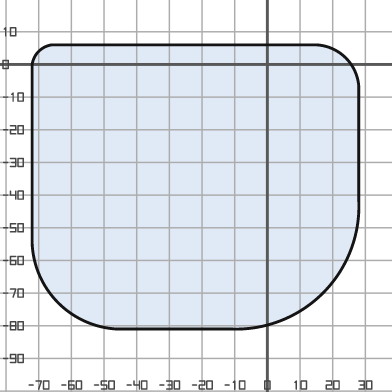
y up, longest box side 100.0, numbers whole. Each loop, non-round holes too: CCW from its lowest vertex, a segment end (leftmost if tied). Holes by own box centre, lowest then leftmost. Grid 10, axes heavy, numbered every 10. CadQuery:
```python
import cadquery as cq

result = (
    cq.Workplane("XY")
    .moveTo(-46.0, -81.0)
    .lineTo(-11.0, -81.0)
    .threePointArc((17.0, -70.0), (28.0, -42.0))
    .lineTo(28.0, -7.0)
    .threePointArc((24.0, 2.0), (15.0, 6.0))
    .lineTo(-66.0, 6.0)
    .threePointArc((-70.0, 4.0), (-72.0, 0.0))
    .lineTo(-72.0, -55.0)
    .threePointArc((-64.0, -73.0), (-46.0, -81.0))
    .close()
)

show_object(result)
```